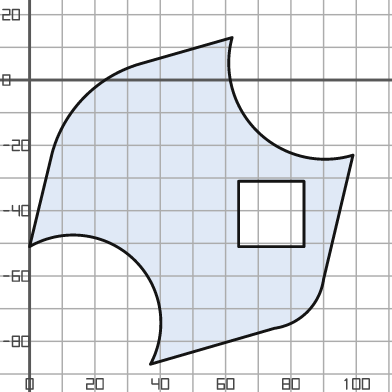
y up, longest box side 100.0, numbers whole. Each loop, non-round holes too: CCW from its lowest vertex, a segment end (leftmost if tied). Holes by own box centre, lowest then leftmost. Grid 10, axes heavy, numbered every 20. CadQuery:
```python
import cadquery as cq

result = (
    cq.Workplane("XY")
    .moveTo(37.0, -87.0)
    .lineTo(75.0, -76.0)
    .threePointArc((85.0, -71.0), (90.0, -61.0))
    .lineTo(99.0, -23.0)
    .threePointArc((70.0, -16.0), (62.0, 13.0))
    .lineTo(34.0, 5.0)
    .threePointArc((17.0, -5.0), (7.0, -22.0))
    .lineTo(0.0, -51.0)
    .threePointArc((32.0, -55.0), (37.0, -87.0))
    .close()
    .moveTo(64.0, -51.0)
    .lineTo(84.0, -51.0)
    .lineTo(84.0, -31.0)
    .lineTo(64.0, -31.0)
    .close()
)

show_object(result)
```